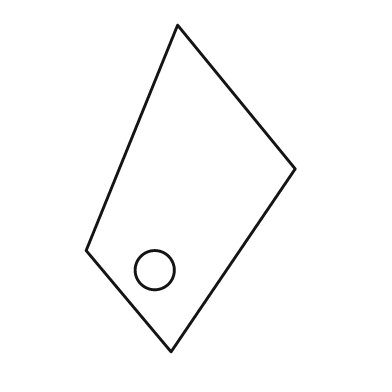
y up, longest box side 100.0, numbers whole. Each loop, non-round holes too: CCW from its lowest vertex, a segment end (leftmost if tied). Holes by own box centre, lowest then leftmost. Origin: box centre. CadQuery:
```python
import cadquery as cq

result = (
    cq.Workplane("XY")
    .moveTo(-6.0, -50.0)
    .lineTo(32.0, 6.0)
    .lineTo(-4.0, 50.0)
    .lineTo(-32.0, -19.0)
    .close()
    .moveTo(-11.0, -25.0)
    .circle(6.0)
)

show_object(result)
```